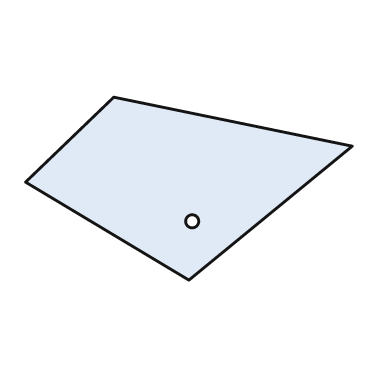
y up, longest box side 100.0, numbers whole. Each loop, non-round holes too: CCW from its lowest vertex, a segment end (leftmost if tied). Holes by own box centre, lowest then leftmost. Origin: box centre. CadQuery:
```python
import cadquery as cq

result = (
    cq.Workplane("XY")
    .moveTo(0.0, -28.0)
    .lineTo(50.0, 13.0)
    .lineTo(-23.0, 28.0)
    .lineTo(-50.0, 2.0)
    .close()
    .moveTo(1.0, -10.0)
    .circle(2.0)
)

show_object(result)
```